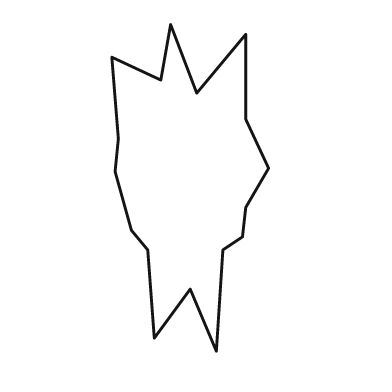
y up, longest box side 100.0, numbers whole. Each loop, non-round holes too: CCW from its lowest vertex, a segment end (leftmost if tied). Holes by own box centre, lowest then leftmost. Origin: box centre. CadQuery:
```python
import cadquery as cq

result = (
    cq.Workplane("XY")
    .moveTo(8.0, -50.0)
    .lineTo(10.0, -19.0)
    .lineTo(16.0, -15.0)
    .lineTo(17.0, -6.0)
    .lineTo(24.0, 6.0)
    .lineTo(17.0, 21.0)
    .lineTo(17.0, 47.0)
    .lineTo(2.0, 29.0)
    .lineTo(-6.0, 50.0)
    .lineTo(-9.0, 33.0)
    .lineTo(-24.0, 40.0)
    .lineTo(-22.0, 15.0)
    .lineTo(-23.0, 5.0)
    .lineTo(-18.0, -13.0)
    .lineTo(-13.0, -19.0)
    .lineTo(-11.0, -46.0)
    .lineTo(0.0, -31.0)
    .close()
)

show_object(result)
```